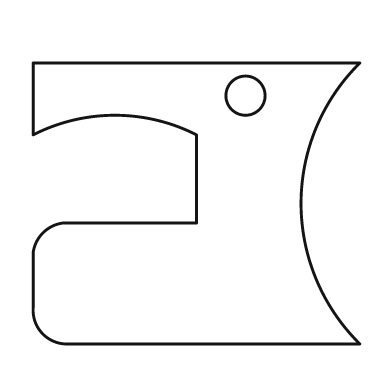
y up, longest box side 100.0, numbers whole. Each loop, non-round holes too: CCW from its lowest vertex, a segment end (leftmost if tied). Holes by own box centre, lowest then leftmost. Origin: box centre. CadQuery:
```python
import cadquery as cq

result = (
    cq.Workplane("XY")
    .moveTo(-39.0, -43.0)
    .lineTo(50.0, -43.0)
    .threePointArc((32.0, 0.0), (50.0, 43.0))
    .lineTo(-50.0, 43.0)
    .lineTo(-50.0, 21.0)
    .threePointArc((-25.0, 27.0), (0.0, 21.0))
    .lineTo(0.0, -6.0)
    .lineTo(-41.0, -6.0)
    .threePointArc((-47.0, -9.0), (-50.0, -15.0))
    .lineTo(-50.0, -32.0)
    .threePointArc((-47.0, -40.0), (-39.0, -43.0))
    .close()
    .moveTo(15.0, 33.0)
    .circle(6.0)
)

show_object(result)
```